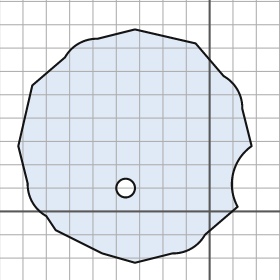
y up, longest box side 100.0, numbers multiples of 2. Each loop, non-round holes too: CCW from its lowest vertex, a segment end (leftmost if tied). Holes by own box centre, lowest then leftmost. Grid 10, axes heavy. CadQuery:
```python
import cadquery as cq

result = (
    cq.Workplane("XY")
    .moveTo(-32.0, -22.0)
    .lineTo(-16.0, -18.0)
    .threePointArc((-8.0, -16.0), (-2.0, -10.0))
    .lineTo(12.0, 2.0)
    .threePointArc((10.0, 16.0), (18.0, 28.0))
    .lineTo(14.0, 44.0)
    .threePointArc((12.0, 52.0), (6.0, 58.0))
    .lineTo(-6.0, 72.0)
    .lineTo(-32.0, 78.0)
    .lineTo(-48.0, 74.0)
    .threePointArc((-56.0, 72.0), (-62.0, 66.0))
    .lineTo(-76.0, 54.0)
    .lineTo(-82.0, 28.0)
    .lineTo(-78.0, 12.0)
    .threePointArc((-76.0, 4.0), (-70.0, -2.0))
    .lineTo(-66.0, -8.0)
    .lineTo(-46.0, -18.0)
    .close()
    .moveTo(-36.0, 10.0)
    .circle(4.0)
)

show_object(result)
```